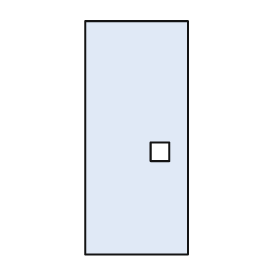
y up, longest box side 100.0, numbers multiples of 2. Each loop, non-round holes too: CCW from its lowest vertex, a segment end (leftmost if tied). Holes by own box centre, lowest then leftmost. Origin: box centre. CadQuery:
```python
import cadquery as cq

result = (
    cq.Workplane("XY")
    .moveTo(-22.0, -50.0)
    .lineTo(22.0, -50.0)
    .lineTo(22.0, 50.0)
    .lineTo(-22.0, 50.0)
    .close()
    .moveTo(6.0, -10.0)
    .lineTo(14.0, -10.0)
    .lineTo(14.0, -2.0)
    .lineTo(6.0, -2.0)
    .close()
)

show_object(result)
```